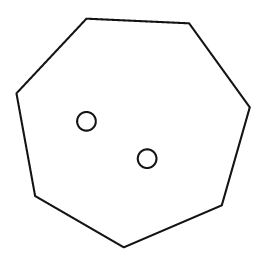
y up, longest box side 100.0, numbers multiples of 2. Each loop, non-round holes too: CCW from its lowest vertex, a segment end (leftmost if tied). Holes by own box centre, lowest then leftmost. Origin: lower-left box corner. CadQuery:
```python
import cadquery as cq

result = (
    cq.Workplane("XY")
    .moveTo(46.0, 0.0)
    .lineTo(88.0, 18.0)
    .lineTo(100.0, 60.0)
    .lineTo(74.0, 96.0)
    .lineTo(30.0, 98.0)
    .lineTo(0.0, 66.0)
    .lineTo(8.0, 22.0)
    .close()
    .moveTo(56.0, 38.0)
    .circle(4.0)
    .moveTo(30.0, 54.0)
    .circle(4.0)
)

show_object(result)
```